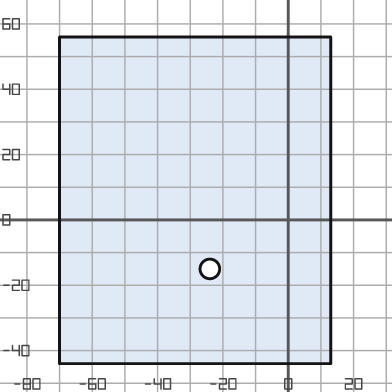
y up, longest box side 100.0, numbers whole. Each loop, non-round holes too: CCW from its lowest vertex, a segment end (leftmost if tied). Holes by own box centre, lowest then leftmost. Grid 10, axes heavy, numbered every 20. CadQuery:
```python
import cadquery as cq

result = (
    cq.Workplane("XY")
    .moveTo(-70.0, -44.0)
    .lineTo(13.0, -44.0)
    .lineTo(13.0, 56.0)
    .lineTo(-70.0, 56.0)
    .close()
    .moveTo(-24.0, -15.0)
    .circle(3.0)
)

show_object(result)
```